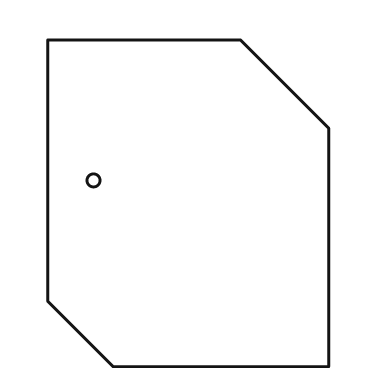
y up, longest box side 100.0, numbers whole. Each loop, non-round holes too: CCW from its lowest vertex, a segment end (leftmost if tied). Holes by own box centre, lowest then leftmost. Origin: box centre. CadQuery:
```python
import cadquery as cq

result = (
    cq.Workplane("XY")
    .moveTo(-23.0, -50.0)
    .lineTo(43.0, -50.0)
    .lineTo(43.0, 23.0)
    .lineTo(16.0, 50.0)
    .lineTo(-43.0, 50.0)
    .lineTo(-43.0, -30.0)
    .close()
    .moveTo(-29.0, 7.0)
    .circle(2.0)
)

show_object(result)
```